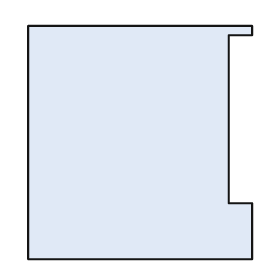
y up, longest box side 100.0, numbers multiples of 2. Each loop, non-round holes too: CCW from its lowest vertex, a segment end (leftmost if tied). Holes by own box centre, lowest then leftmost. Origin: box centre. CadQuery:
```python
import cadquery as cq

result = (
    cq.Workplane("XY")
    .moveTo(-48.0, -50.0)
    .lineTo(48.0, -50.0)
    .lineTo(48.0, -26.0)
    .lineTo(38.0, -26.0)
    .lineTo(38.0, 46.0)
    .lineTo(48.0, 46.0)
    .lineTo(48.0, 50.0)
    .lineTo(-48.0, 50.0)
    .close()
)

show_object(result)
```